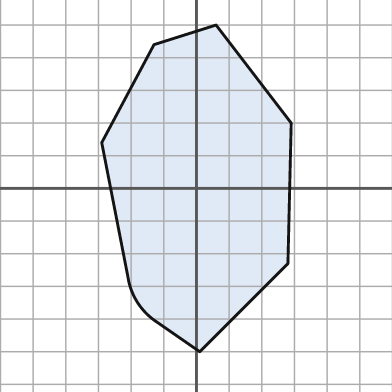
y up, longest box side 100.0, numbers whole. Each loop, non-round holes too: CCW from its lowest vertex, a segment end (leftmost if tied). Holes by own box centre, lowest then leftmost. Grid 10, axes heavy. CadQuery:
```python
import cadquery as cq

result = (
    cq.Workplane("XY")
    .moveTo(1.0, -50.0)
    .lineTo(28.0, -23.0)
    .lineTo(29.0, 20.0)
    .lineTo(6.0, 50.0)
    .lineTo(-13.0, 44.0)
    .lineTo(-29.0, 14.0)
    .lineTo(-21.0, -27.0)
    .threePointArc((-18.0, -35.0), (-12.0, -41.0))
    .close()
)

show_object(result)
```